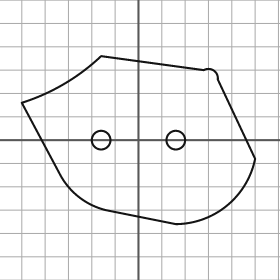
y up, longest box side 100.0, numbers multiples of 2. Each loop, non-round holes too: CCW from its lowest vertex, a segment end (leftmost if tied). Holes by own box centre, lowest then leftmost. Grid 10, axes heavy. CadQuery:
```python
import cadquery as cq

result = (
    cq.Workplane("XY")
    .moveTo(16.0, -36.0)
    .threePointArc((38.0, -28.0), (50.0, -8.0))
    .lineTo(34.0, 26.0)
    .threePointArc((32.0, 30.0), (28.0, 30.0))
    .lineTo(-16.0, 36.0)
    .threePointArc((-32.0, 24.0), (-50.0, 16.0))
    .lineTo(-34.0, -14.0)
    .threePointArc((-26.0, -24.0), (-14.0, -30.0))
    .close()
    .moveTo(-16.0, 0.0)
    .circle(4.0)
    .moveTo(16.0, 0.0)
    .circle(4.0)
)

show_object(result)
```